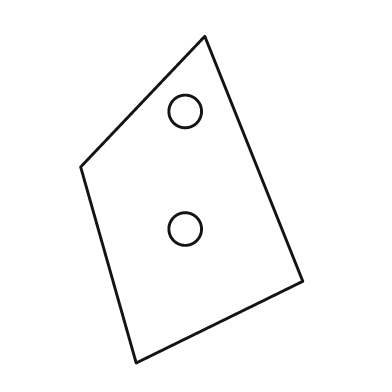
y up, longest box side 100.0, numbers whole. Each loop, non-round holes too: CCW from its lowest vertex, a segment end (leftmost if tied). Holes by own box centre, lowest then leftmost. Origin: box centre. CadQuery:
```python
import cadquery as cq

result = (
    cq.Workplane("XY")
    .moveTo(-17.0, -50.0)
    .lineTo(34.0, -25.0)
    .lineTo(4.0, 50.0)
    .lineTo(-34.0, 10.0)
    .close()
    .moveTo(-2.0, -9.0)
    .circle(5.0)
    .moveTo(-2.0, 27.0)
    .circle(5.0)
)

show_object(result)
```